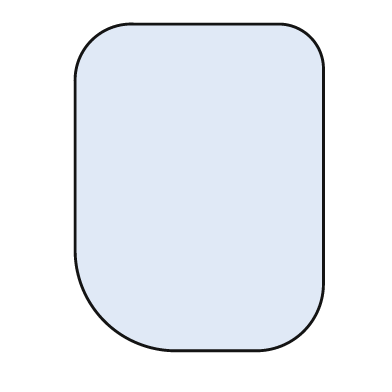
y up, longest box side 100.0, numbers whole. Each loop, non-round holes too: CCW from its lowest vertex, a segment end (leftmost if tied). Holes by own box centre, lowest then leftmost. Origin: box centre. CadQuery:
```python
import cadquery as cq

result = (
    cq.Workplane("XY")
    .moveTo(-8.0, -50.0)
    .lineTo(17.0, -50.0)
    .threePointArc((32.0, -44.0), (38.0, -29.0))
    .lineTo(38.0, 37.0)
    .threePointArc((34.0, 46.0), (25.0, 50.0))
    .lineTo(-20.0, 50.0)
    .threePointArc((-33.0, 45.0), (-38.0, 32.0))
    .lineTo(-38.0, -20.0)
    .threePointArc((-29.0, -41.0), (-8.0, -50.0))
    .close()
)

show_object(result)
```